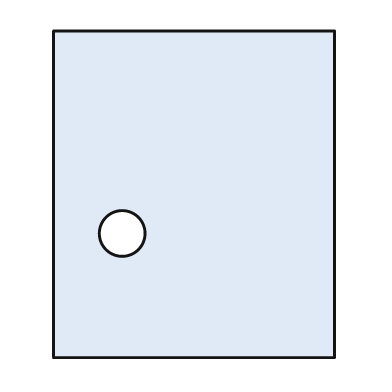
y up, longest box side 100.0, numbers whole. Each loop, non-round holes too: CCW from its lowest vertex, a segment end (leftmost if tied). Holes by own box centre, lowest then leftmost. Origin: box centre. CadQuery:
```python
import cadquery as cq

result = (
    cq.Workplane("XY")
    .moveTo(-43.0, -50.0)
    .lineTo(43.0, -50.0)
    .lineTo(43.0, 50.0)
    .lineTo(-43.0, 50.0)
    .close()
    .moveTo(-22.0, -12.0)
    .circle(7.0)
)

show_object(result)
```